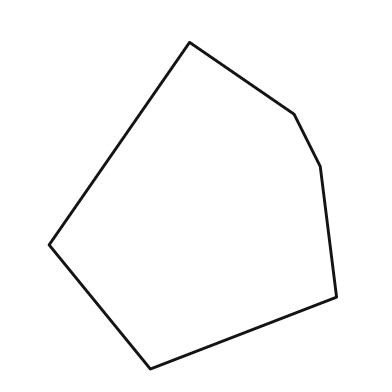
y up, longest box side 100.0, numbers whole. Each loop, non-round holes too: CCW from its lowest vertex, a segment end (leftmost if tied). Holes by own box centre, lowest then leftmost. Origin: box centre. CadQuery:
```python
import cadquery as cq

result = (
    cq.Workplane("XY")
    .moveTo(-13.0, -50.0)
    .lineTo(44.0, -28.0)
    .lineTo(39.0, 12.0)
    .lineTo(31.0, 28.0)
    .lineTo(-1.0, 50.0)
    .lineTo(-44.0, -12.0)
    .close()
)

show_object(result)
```